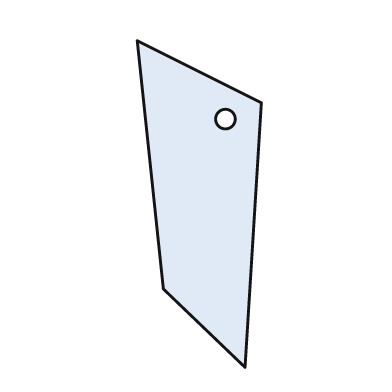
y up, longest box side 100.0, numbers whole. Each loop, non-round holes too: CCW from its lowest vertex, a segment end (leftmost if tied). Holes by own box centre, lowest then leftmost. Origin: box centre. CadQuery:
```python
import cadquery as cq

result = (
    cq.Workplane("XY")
    .moveTo(14.0, -50.0)
    .lineTo(19.0, 31.0)
    .lineTo(-19.0, 50.0)
    .lineTo(-11.0, -26.0)
    .close()
    .moveTo(8.0, 26.0)
    .circle(3.0)
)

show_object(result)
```